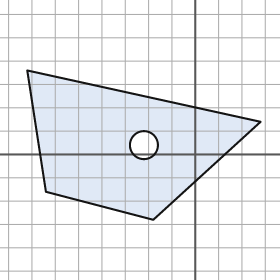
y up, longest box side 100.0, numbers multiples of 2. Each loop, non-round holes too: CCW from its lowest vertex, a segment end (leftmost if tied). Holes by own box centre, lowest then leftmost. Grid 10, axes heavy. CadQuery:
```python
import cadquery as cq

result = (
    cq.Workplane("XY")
    .moveTo(-18.0, -28.0)
    .lineTo(28.0, 14.0)
    .lineTo(-72.0, 36.0)
    .lineTo(-64.0, -16.0)
    .close()
    .moveTo(-22.0, 4.0)
    .circle(6.0)
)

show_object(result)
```